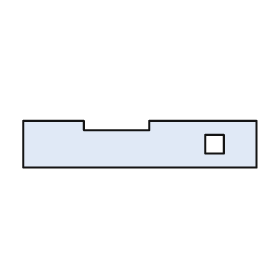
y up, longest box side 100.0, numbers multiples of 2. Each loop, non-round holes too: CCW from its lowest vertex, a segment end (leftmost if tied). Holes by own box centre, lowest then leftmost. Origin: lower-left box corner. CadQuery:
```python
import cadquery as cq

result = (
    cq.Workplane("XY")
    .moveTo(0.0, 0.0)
    .lineTo(100.0, 0.0)
    .lineTo(100.0, 20.0)
    .lineTo(54.0, 20.0)
    .lineTo(54.0, 16.0)
    .lineTo(26.0, 16.0)
    .lineTo(26.0, 20.0)
    .lineTo(0.0, 20.0)
    .close()
    .moveTo(78.0, 6.0)
    .lineTo(86.0, 6.0)
    .lineTo(86.0, 14.0)
    .lineTo(78.0, 14.0)
    .close()
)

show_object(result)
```